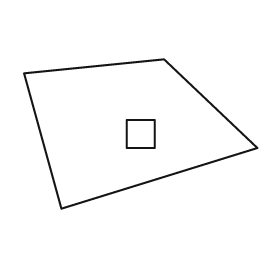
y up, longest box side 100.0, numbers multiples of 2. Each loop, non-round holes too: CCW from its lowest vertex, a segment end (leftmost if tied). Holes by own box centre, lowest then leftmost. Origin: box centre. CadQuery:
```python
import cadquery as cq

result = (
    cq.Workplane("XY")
    .moveTo(-34.0, -32.0)
    .lineTo(50.0, -6.0)
    .lineTo(10.0, 32.0)
    .lineTo(-50.0, 26.0)
    .close()
    .moveTo(-6.0, -6.0)
    .lineTo(6.0, -6.0)
    .lineTo(6.0, 6.0)
    .lineTo(-6.0, 6.0)
    .close()
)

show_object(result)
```